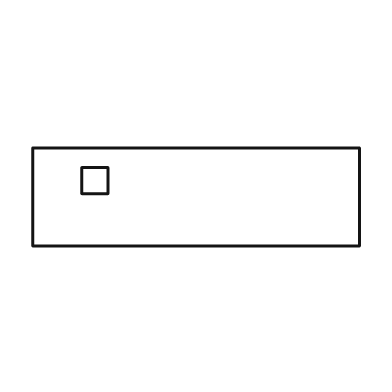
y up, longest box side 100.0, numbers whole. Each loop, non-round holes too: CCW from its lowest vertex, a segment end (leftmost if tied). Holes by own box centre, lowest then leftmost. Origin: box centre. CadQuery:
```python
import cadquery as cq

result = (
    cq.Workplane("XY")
    .moveTo(-50.0, -15.0)
    .lineTo(50.0, -15.0)
    .lineTo(50.0, 15.0)
    .lineTo(-50.0, 15.0)
    .close()
    .moveTo(-35.0, 1.0)
    .lineTo(-27.0, 1.0)
    .lineTo(-27.0, 9.0)
    .lineTo(-35.0, 9.0)
    .close()
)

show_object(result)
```